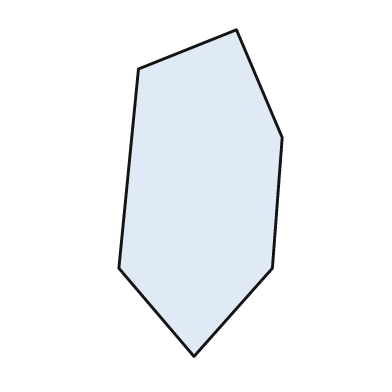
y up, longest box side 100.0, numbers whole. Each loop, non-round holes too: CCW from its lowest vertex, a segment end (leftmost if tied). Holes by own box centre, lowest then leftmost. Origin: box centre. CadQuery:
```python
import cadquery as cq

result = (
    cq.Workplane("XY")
    .moveTo(-2.0, -50.0)
    .lineTo(22.0, -23.0)
    .lineTo(25.0, 17.0)
    .lineTo(11.0, 50.0)
    .lineTo(-19.0, 38.0)
    .lineTo(-25.0, -23.0)
    .close()
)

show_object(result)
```